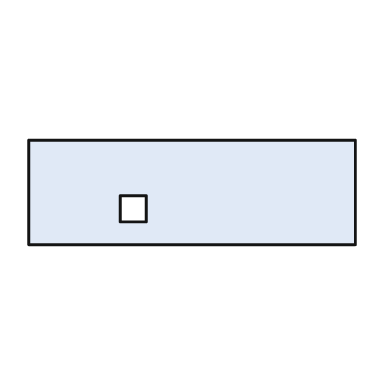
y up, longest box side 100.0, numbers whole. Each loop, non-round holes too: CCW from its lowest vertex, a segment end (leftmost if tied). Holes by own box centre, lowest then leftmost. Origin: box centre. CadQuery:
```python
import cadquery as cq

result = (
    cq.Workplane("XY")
    .moveTo(-50.0, -16.0)
    .lineTo(50.0, -16.0)
    .lineTo(50.0, 16.0)
    .lineTo(-50.0, 16.0)
    .close()
    .moveTo(-22.0, -9.0)
    .lineTo(-14.0, -9.0)
    .lineTo(-14.0, -1.0)
    .lineTo(-22.0, -1.0)
    .close()
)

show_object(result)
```